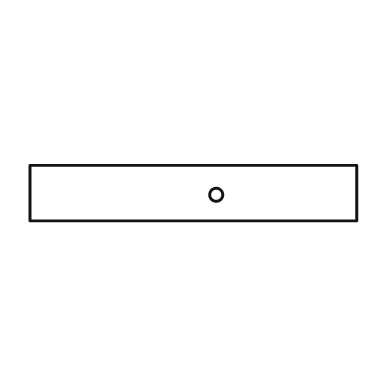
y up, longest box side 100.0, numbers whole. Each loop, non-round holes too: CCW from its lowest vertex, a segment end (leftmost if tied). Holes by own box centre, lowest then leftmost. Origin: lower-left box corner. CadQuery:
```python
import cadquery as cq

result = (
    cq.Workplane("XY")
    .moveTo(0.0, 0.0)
    .lineTo(100.0, 0.0)
    .lineTo(100.0, 17.0)
    .lineTo(0.0, 17.0)
    .close()
    .moveTo(57.0, 8.0)
    .circle(2.0)
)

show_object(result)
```